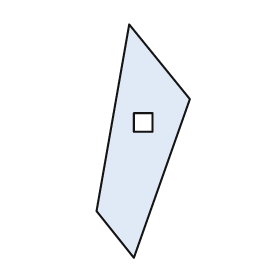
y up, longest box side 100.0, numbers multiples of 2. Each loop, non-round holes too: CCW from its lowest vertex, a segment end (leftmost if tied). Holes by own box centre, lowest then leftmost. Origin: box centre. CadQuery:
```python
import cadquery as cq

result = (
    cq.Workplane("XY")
    .moveTo(-4.0, -50.0)
    .lineTo(20.0, 18.0)
    .lineTo(-6.0, 50.0)
    .lineTo(-20.0, -30.0)
    .close()
    .moveTo(-4.0, 4.0)
    .lineTo(4.0, 4.0)
    .lineTo(4.0, 12.0)
    .lineTo(-4.0, 12.0)
    .close()
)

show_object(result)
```